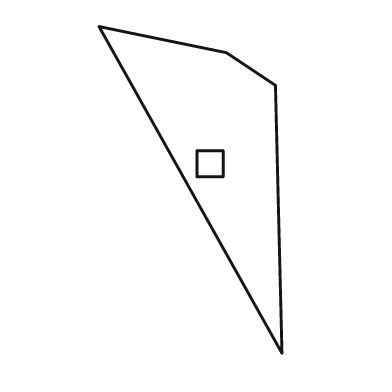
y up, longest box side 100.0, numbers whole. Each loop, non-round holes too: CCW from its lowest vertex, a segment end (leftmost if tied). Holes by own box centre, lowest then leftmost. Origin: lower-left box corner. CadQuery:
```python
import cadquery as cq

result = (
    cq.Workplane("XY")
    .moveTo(56.0, 0.0)
    .lineTo(54.0, 82.0)
    .lineTo(39.0, 92.0)
    .lineTo(0.0, 100.0)
    .close()
    .moveTo(30.0, 54.0)
    .lineTo(38.0, 54.0)
    .lineTo(38.0, 62.0)
    .lineTo(30.0, 62.0)
    .close()
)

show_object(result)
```